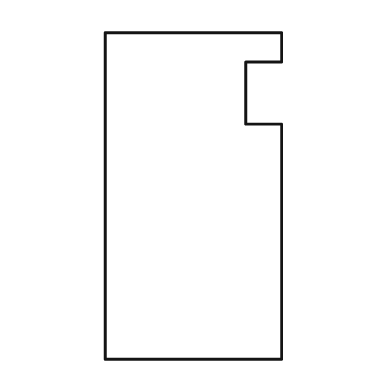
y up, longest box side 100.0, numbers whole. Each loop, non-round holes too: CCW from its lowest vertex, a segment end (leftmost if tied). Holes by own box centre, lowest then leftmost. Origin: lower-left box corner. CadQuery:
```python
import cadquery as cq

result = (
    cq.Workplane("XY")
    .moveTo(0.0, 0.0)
    .lineTo(54.0, 0.0)
    .lineTo(54.0, 72.0)
    .lineTo(43.0, 72.0)
    .lineTo(43.0, 91.0)
    .lineTo(54.0, 91.0)
    .lineTo(54.0, 100.0)
    .lineTo(0.0, 100.0)
    .close()
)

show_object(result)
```